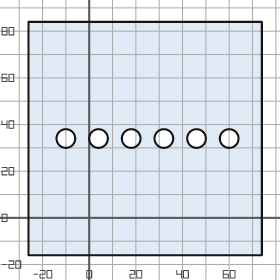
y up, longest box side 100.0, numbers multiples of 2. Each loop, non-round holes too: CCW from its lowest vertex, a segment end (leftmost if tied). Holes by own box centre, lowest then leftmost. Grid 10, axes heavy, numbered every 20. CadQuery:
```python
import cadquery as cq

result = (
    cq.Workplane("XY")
    .moveTo(-26.0, -16.0)
    .lineTo(74.0, -16.0)
    .lineTo(74.0, 84.0)
    .lineTo(-26.0, 84.0)
    .close()
    .moveTo(-10.0, 34.0)
    .circle(4.0)
    .moveTo(4.0, 34.0)
    .circle(4.0)
    .moveTo(18.0, 34.0)
    .circle(4.0)
    .moveTo(32.0, 34.0)
    .circle(4.0)
    .moveTo(46.0, 34.0)
    .circle(4.0)
    .moveTo(60.0, 34.0)
    .circle(4.0)
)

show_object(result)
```